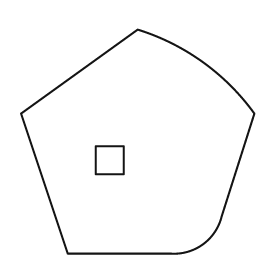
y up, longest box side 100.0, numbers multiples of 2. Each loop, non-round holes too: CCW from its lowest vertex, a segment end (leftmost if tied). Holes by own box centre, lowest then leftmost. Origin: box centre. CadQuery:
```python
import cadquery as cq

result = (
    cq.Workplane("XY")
    .moveTo(-30.0, -48.0)
    .lineTo(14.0, -48.0)
    .threePointArc((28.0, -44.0), (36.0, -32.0))
    .lineTo(50.0, 12.0)
    .threePointArc((28.0, 34.0), (0.0, 48.0))
    .lineTo(-50.0, 12.0)
    .close()
    .moveTo(-18.0, -14.0)
    .lineTo(-6.0, -14.0)
    .lineTo(-6.0, -2.0)
    .lineTo(-18.0, -2.0)
    .close()
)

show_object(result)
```